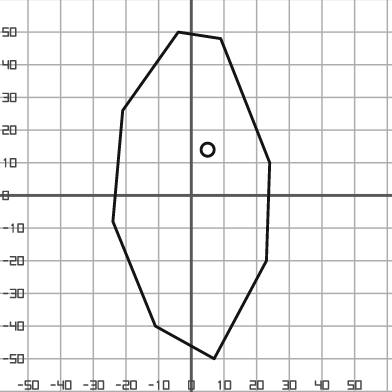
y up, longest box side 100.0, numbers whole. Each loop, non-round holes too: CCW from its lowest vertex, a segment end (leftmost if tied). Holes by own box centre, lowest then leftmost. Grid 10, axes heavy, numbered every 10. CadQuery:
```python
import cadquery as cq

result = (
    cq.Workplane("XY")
    .moveTo(7.0, -50.0)
    .lineTo(23.0, -20.0)
    .lineTo(24.0, 10.0)
    .lineTo(9.0, 48.0)
    .lineTo(-4.0, 50.0)
    .lineTo(-21.0, 26.0)
    .lineTo(-24.0, -8.0)
    .lineTo(-11.0, -40.0)
    .close()
    .moveTo(5.0, 14.0)
    .circle(2.0)
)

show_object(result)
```